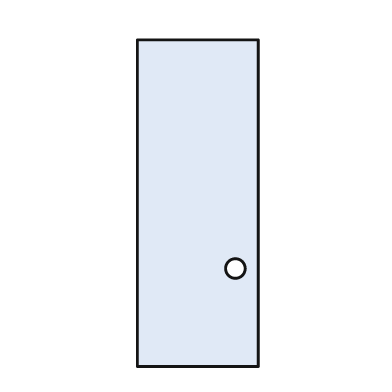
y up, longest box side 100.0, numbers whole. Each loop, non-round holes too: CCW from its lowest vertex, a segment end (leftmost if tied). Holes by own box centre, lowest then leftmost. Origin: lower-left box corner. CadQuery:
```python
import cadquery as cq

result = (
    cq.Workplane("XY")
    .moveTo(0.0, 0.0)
    .lineTo(37.0, 0.0)
    .lineTo(37.0, 100.0)
    .lineTo(0.0, 100.0)
    .close()
    .moveTo(30.0, 30.0)
    .circle(3.0)
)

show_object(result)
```